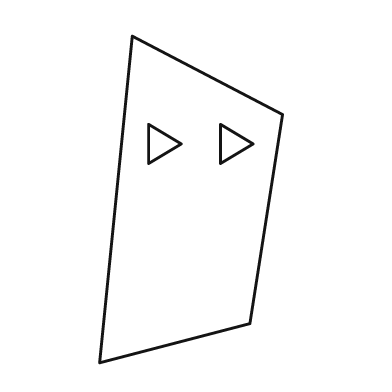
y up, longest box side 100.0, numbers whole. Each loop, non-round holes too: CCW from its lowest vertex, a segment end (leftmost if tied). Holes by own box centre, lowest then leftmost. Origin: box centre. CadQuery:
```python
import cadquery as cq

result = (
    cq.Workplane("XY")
    .moveTo(-28.0, -50.0)
    .lineTo(18.0, -38.0)
    .lineTo(28.0, 26.0)
    .lineTo(-18.0, 50.0)
    .close()
    .moveTo(-13.0, 11.0)
    .lineTo(-3.0, 17.0)
    .lineTo(-13.0, 23.0)
    .close()
    .moveTo(9.0, 11.0)
    .lineTo(19.0, 17.0)
    .lineTo(9.0, 23.0)
    .close()
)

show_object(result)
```